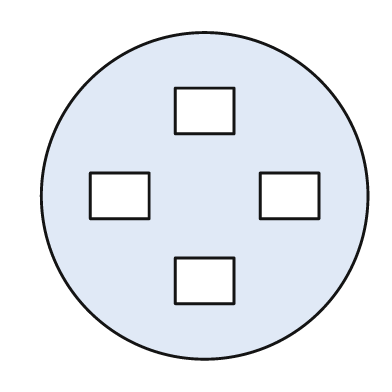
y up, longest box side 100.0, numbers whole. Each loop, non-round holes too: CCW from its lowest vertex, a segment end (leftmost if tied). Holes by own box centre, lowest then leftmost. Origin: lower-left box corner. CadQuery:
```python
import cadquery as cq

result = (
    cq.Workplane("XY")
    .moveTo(50.0, 50.0)
    .circle(50.0)
    .moveTo(41.0, 17.0)
    .lineTo(59.0, 17.0)
    .lineTo(59.0, 31.0)
    .lineTo(41.0, 31.0)
    .close()
    .moveTo(15.0, 43.0)
    .lineTo(33.0, 43.0)
    .lineTo(33.0, 57.0)
    .lineTo(15.0, 57.0)
    .close()
    .moveTo(67.0, 43.0)
    .lineTo(85.0, 43.0)
    .lineTo(85.0, 57.0)
    .lineTo(67.0, 57.0)
    .close()
    .moveTo(41.0, 69.0)
    .lineTo(59.0, 69.0)
    .lineTo(59.0, 83.0)
    .lineTo(41.0, 83.0)
    .close()
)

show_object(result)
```